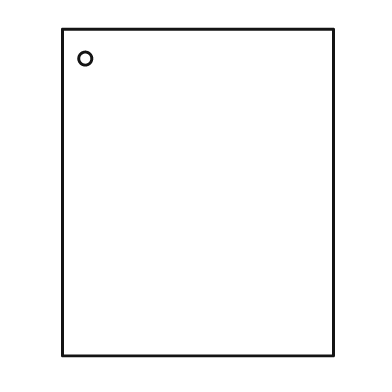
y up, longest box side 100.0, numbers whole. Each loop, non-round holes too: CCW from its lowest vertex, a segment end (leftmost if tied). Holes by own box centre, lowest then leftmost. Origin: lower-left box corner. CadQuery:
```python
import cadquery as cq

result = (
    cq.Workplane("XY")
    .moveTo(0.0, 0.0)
    .lineTo(83.0, 0.0)
    .lineTo(83.0, 100.0)
    .lineTo(0.0, 100.0)
    .close()
    .moveTo(7.0, 91.0)
    .circle(2.0)
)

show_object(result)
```